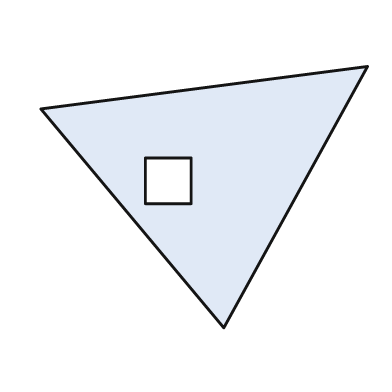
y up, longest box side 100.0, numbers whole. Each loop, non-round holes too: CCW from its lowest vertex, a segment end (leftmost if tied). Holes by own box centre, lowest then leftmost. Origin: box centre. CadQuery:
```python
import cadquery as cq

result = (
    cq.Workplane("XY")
    .moveTo(6.0, -40.0)
    .lineTo(50.0, 40.0)
    .lineTo(-50.0, 27.0)
    .close()
    .moveTo(-18.0, -2.0)
    .lineTo(-4.0, -2.0)
    .lineTo(-4.0, 12.0)
    .lineTo(-18.0, 12.0)
    .close()
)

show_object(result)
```